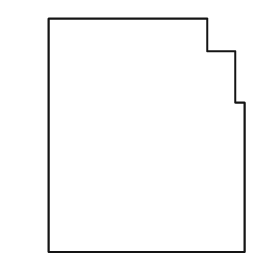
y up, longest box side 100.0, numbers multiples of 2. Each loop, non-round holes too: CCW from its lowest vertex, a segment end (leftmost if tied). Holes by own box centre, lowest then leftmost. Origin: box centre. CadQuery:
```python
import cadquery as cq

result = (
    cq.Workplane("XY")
    .moveTo(-42.0, -50.0)
    .lineTo(42.0, -50.0)
    .lineTo(42.0, 14.0)
    .lineTo(38.0, 14.0)
    .lineTo(38.0, 36.0)
    .lineTo(26.0, 36.0)
    .lineTo(26.0, 50.0)
    .lineTo(-42.0, 50.0)
    .close()
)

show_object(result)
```